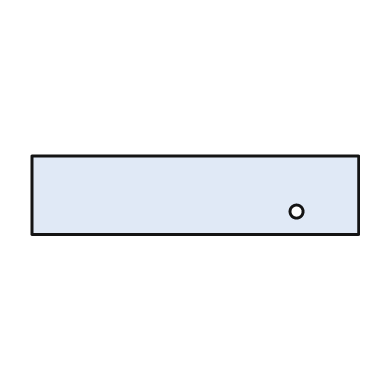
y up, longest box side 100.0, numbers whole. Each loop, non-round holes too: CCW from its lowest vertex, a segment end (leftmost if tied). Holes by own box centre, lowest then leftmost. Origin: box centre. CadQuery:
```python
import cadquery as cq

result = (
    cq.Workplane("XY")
    .moveTo(-50.0, -12.0)
    .lineTo(50.0, -12.0)
    .lineTo(50.0, 12.0)
    .lineTo(-50.0, 12.0)
    .close()
    .moveTo(31.0, -5.0)
    .circle(2.0)
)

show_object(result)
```